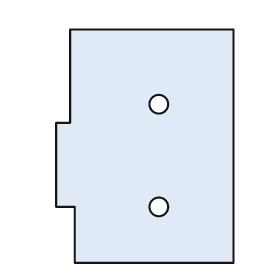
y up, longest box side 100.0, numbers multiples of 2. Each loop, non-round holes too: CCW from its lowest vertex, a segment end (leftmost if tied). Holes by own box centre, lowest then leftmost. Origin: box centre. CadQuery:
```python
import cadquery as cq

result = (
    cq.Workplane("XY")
    .moveTo(-30.0, -50.0)
    .lineTo(38.0, -50.0)
    .lineTo(38.0, 50.0)
    .lineTo(-32.0, 50.0)
    .lineTo(-32.0, 10.0)
    .lineTo(-38.0, 10.0)
    .lineTo(-38.0, -26.0)
    .lineTo(-30.0, -26.0)
    .close()
    .moveTo(6.0, -26.0)
    .circle(4.0)
    .moveTo(6.0, 18.0)
    .circle(4.0)
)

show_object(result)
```